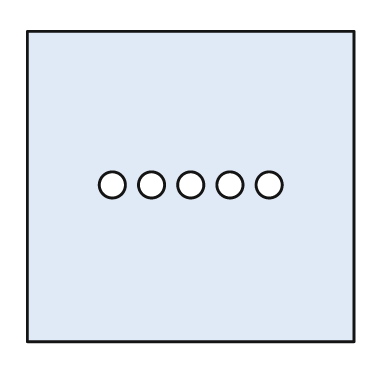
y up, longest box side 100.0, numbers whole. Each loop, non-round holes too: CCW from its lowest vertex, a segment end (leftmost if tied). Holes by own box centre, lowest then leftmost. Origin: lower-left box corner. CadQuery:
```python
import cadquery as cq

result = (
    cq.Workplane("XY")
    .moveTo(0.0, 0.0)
    .lineTo(100.0, 0.0)
    .lineTo(100.0, 95.0)
    .lineTo(0.0, 95.0)
    .close()
    .moveTo(26.0, 48.0)
    .circle(4.0)
    .moveTo(38.0, 48.0)
    .circle(4.0)
    .moveTo(50.0, 48.0)
    .circle(4.0)
    .moveTo(62.0, 48.0)
    .circle(4.0)
    .moveTo(74.0, 48.0)
    .circle(4.0)
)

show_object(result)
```